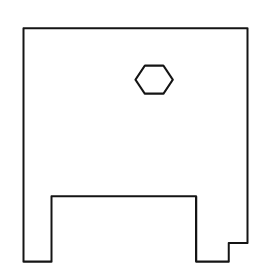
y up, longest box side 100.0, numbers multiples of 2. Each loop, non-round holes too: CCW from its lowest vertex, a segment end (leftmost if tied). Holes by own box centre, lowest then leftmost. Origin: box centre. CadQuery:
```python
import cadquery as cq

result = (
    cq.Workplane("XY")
    .moveTo(-48.0, -50.0)
    .lineTo(-36.0, -50.0)
    .lineTo(-36.0, -22.0)
    .lineTo(26.0, -22.0)
    .lineTo(26.0, -50.0)
    .lineTo(40.0, -50.0)
    .lineTo(40.0, -42.0)
    .lineTo(48.0, -42.0)
    .lineTo(48.0, 50.0)
    .lineTo(-48.0, 50.0)
    .close()
    .moveTo(4.0, 22.0)
    .lineTo(12.0, 22.0)
    .lineTo(16.0, 28.0)
    .lineTo(12.0, 34.0)
    .lineTo(4.0, 34.0)
    .lineTo(0.0, 28.0)
    .close()
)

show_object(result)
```